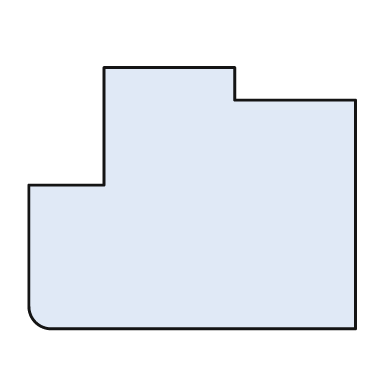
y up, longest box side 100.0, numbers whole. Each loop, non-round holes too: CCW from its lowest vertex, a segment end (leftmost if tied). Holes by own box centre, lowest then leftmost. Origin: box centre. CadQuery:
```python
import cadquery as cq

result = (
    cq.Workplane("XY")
    .moveTo(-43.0, -40.0)
    .lineTo(50.0, -40.0)
    .lineTo(50.0, 30.0)
    .lineTo(13.0, 30.0)
    .lineTo(13.0, 40.0)
    .lineTo(-27.0, 40.0)
    .lineTo(-27.0, 4.0)
    .lineTo(-50.0, 4.0)
    .lineTo(-50.0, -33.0)
    .threePointArc((-48.0, -38.0), (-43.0, -40.0))
    .close()
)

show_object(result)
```